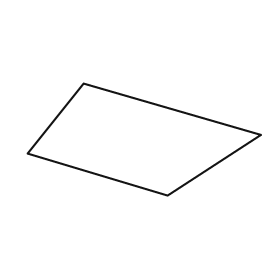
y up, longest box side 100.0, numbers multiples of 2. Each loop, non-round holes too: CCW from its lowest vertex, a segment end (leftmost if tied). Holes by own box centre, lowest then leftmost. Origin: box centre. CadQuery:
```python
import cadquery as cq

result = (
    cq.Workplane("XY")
    .moveTo(10.0, -24.0)
    .lineTo(50.0, 2.0)
    .lineTo(-26.0, 24.0)
    .lineTo(-50.0, -6.0)
    .close()
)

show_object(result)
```